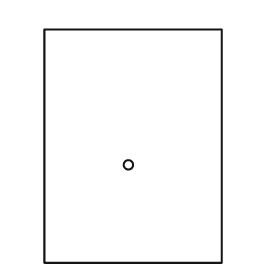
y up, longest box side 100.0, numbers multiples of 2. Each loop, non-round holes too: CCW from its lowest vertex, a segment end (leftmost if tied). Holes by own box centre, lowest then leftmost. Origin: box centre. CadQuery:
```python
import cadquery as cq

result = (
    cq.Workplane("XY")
    .moveTo(-38.0, -50.0)
    .lineTo(38.0, -50.0)
    .lineTo(38.0, 50.0)
    .lineTo(-38.0, 50.0)
    .close()
    .moveTo(-2.0, -8.0)
    .circle(2.0)
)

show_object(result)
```